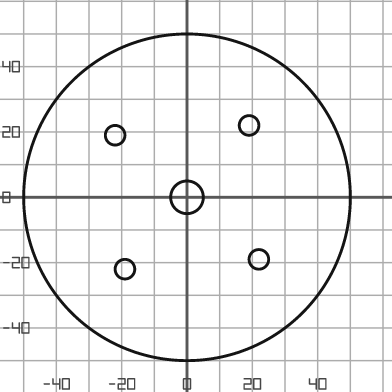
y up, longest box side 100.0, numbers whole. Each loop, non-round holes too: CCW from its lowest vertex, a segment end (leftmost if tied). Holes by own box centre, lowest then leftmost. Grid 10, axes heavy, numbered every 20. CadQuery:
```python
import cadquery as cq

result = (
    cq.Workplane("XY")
    .moveTo(0.0, 0.0)
    .circle(50.0)
    .moveTo(-19.0, -22.0)
    .circle(3.0)
    .moveTo(22.0, -19.0)
    .circle(3.0)
    .moveTo(0.0, 0.0)
    .circle(5.0)
    .moveTo(-22.0, 19.0)
    .circle(3.0)
    .moveTo(19.0, 22.0)
    .circle(3.0)
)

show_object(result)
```